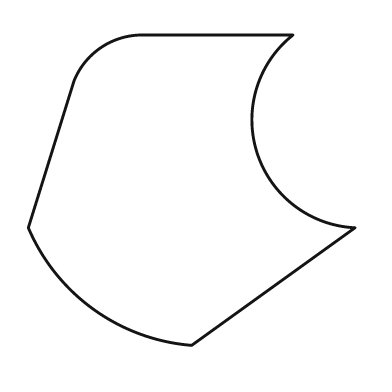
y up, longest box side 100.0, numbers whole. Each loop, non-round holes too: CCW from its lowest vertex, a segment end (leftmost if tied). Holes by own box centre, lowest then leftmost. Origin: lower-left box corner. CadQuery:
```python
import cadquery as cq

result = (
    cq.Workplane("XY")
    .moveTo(50.0, 0.0)
    .lineTo(100.0, 36.0)
    .threePointArc((70.0, 59.0), (81.0, 95.0))
    .lineTo(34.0, 95.0)
    .threePointArc((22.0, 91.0), (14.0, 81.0))
    .lineTo(0.0, 36.0)
    .threePointArc((20.0, 11.0), (50.0, 0.0))
    .close()
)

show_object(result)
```